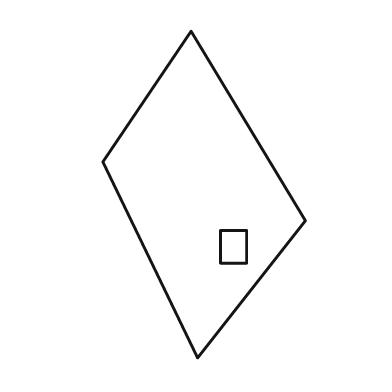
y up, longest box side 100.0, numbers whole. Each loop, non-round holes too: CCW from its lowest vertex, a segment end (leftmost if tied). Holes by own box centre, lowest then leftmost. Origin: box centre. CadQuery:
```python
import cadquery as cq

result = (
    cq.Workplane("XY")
    .moveTo(-2.0, -50.0)
    .lineTo(31.0, -8.0)
    .lineTo(-4.0, 50.0)
    .lineTo(-31.0, 10.0)
    .close()
    .moveTo(5.0, -21.0)
    .lineTo(13.0, -21.0)
    .lineTo(13.0, -11.0)
    .lineTo(5.0, -11.0)
    .close()
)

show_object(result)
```